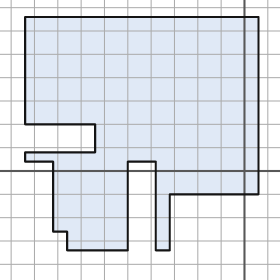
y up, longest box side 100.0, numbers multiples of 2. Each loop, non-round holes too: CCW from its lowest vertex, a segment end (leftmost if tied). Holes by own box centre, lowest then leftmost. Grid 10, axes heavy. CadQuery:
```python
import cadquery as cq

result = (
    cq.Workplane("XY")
    .moveTo(-76.0, -34.0)
    .lineTo(-50.0, -34.0)
    .lineTo(-50.0, 4.0)
    .lineTo(-38.0, 4.0)
    .lineTo(-38.0, -34.0)
    .lineTo(-32.0, -34.0)
    .lineTo(-32.0, -10.0)
    .lineTo(6.0, -10.0)
    .lineTo(6.0, 66.0)
    .lineTo(-94.0, 66.0)
    .lineTo(-94.0, 20.0)
    .lineTo(-64.0, 20.0)
    .lineTo(-64.0, 8.0)
    .lineTo(-94.0, 8.0)
    .lineTo(-94.0, 4.0)
    .lineTo(-82.0, 4.0)
    .lineTo(-82.0, -26.0)
    .lineTo(-76.0, -26.0)
    .close()
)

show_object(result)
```